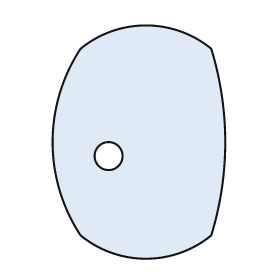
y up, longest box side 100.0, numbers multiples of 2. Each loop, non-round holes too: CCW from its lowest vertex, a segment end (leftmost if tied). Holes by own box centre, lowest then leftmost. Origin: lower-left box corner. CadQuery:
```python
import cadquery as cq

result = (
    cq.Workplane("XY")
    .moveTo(12.0, 10.0)
    .threePointArc((40.0, 0.0), (68.0, 10.0))
    .threePointArc((74.0, 50.0), (68.0, 90.0))
    .threePointArc((40.0, 100.0), (12.0, 90.0))
    .threePointArc((0.0, 50.0), (12.0, 10.0))
    .close()
    .moveTo(24.0, 44.0)
    .circle(6.0)
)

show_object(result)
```